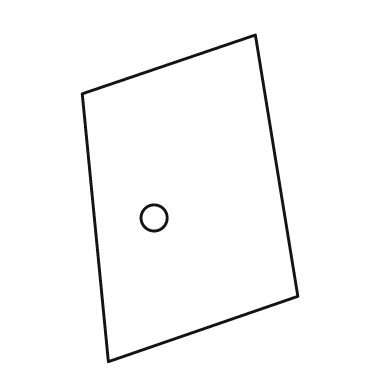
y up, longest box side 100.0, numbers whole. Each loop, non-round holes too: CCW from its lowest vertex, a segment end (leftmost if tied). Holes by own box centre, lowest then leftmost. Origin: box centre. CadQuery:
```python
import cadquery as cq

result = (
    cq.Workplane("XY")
    .moveTo(-25.0, -50.0)
    .lineTo(33.0, -30.0)
    .lineTo(20.0, 50.0)
    .lineTo(-33.0, 32.0)
    .close()
    .moveTo(-11.0, -6.0)
    .circle(4.0)
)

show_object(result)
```